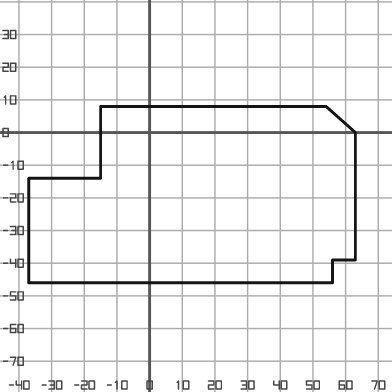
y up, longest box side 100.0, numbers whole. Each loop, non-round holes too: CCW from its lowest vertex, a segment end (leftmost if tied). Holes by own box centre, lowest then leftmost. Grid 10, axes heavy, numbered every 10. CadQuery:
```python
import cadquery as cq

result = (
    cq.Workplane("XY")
    .moveTo(-37.0, -46.0)
    .lineTo(56.0, -46.0)
    .lineTo(56.0, -39.0)
    .lineTo(63.0, -39.0)
    .lineTo(63.0, 0.0)
    .lineTo(54.0, 8.0)
    .lineTo(-15.0, 8.0)
    .lineTo(-15.0, -14.0)
    .lineTo(-37.0, -14.0)
    .close()
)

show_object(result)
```